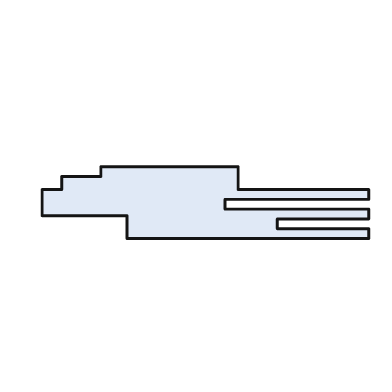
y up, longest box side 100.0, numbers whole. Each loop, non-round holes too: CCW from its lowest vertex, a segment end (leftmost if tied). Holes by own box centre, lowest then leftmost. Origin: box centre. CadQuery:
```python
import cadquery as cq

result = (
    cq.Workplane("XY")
    .moveTo(-24.0, -11.0)
    .lineTo(50.0, -11.0)
    .lineTo(50.0, -8.0)
    .lineTo(22.0, -8.0)
    .lineTo(22.0, -5.0)
    .lineTo(50.0, -5.0)
    .lineTo(50.0, -2.0)
    .lineTo(6.0, -2.0)
    .lineTo(6.0, 1.0)
    .lineTo(50.0, 1.0)
    .lineTo(50.0, 4.0)
    .lineTo(10.0, 4.0)
    .lineTo(10.0, 11.0)
    .lineTo(-32.0, 11.0)
    .lineTo(-32.0, 8.0)
    .lineTo(-44.0, 8.0)
    .lineTo(-44.0, 4.0)
    .lineTo(-50.0, 4.0)
    .lineTo(-50.0, -4.0)
    .lineTo(-24.0, -4.0)
    .close()
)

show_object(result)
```